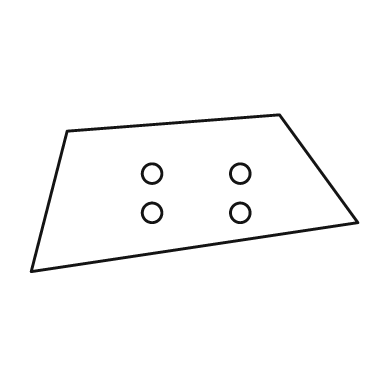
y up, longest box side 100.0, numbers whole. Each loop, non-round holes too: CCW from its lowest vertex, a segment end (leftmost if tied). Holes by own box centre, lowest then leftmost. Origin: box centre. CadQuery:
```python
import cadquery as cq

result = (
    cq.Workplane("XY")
    .moveTo(-50.0, -24.0)
    .lineTo(50.0, -9.0)
    .lineTo(26.0, 24.0)
    .lineTo(-39.0, 19.0)
    .close()
    .moveTo(-13.0, -6.0)
    .circle(3.0)
    .moveTo(14.0, -6.0)
    .circle(3.0)
    .moveTo(-13.0, 6.0)
    .circle(3.0)
    .moveTo(14.0, 6.0)
    .circle(3.0)
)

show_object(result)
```